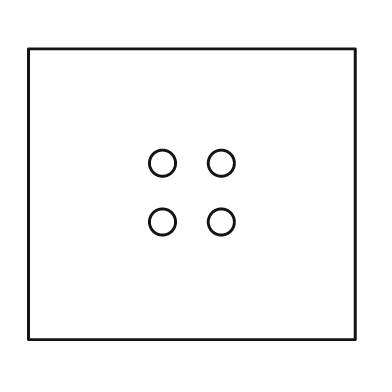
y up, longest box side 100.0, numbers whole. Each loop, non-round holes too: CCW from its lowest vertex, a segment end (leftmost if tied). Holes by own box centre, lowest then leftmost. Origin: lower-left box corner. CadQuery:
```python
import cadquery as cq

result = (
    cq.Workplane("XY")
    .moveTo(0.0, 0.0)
    .lineTo(100.0, 0.0)
    .lineTo(100.0, 89.0)
    .lineTo(0.0, 89.0)
    .close()
    .moveTo(41.0, 36.0)
    .circle(4.0)
    .moveTo(59.0, 36.0)
    .circle(4.0)
    .moveTo(41.0, 54.0)
    .circle(4.0)
    .moveTo(59.0, 54.0)
    .circle(4.0)
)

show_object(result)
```